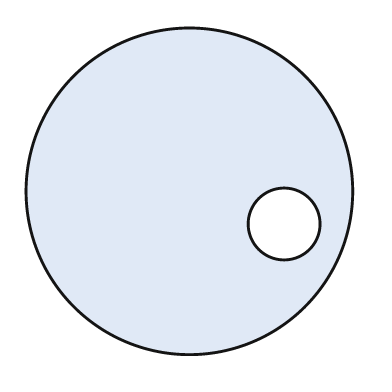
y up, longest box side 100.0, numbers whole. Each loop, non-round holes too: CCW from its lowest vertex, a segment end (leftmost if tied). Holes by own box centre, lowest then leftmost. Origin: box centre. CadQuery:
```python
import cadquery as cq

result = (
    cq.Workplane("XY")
    .moveTo(0.0, 0.0)
    .circle(50.0)
    .moveTo(29.0, -10.0)
    .circle(11.0)
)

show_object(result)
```